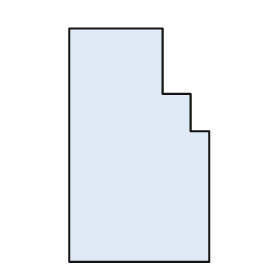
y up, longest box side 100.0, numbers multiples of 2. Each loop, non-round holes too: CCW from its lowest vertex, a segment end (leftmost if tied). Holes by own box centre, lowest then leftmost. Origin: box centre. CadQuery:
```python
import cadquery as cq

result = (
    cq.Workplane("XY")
    .moveTo(-30.0, -50.0)
    .lineTo(30.0, -50.0)
    .lineTo(30.0, 6.0)
    .lineTo(22.0, 6.0)
    .lineTo(22.0, 22.0)
    .lineTo(10.0, 22.0)
    .lineTo(10.0, 50.0)
    .lineTo(-30.0, 50.0)
    .close()
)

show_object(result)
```